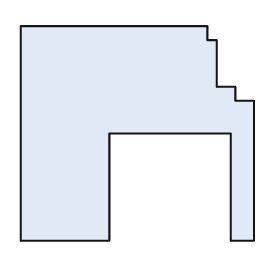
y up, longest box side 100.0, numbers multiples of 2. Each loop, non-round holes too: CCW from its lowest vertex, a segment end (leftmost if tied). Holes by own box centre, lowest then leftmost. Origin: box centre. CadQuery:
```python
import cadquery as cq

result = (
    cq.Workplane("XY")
    .moveTo(-50.0, -46.0)
    .lineTo(-12.0, -46.0)
    .lineTo(-12.0, 0.0)
    .lineTo(40.0, 0.0)
    .lineTo(40.0, -46.0)
    .lineTo(50.0, -46.0)
    .lineTo(50.0, 14.0)
    .lineTo(42.0, 14.0)
    .lineTo(42.0, 20.0)
    .lineTo(34.0, 20.0)
    .lineTo(34.0, 40.0)
    .lineTo(30.0, 40.0)
    .lineTo(30.0, 46.0)
    .lineTo(-50.0, 46.0)
    .close()
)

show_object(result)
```